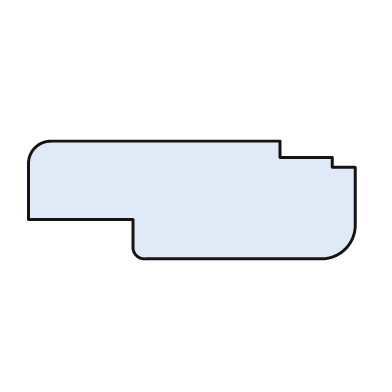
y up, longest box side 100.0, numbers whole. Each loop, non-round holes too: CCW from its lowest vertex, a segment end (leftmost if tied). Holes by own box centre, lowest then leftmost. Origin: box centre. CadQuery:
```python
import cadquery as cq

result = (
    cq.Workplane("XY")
    .moveTo(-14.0, -18.0)
    .lineTo(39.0, -18.0)
    .threePointArc((47.0, -15.0), (50.0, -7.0))
    .lineTo(50.0, 10.0)
    .lineTo(43.0, 10.0)
    .lineTo(43.0, 13.0)
    .lineTo(27.0, 13.0)
    .lineTo(27.0, 18.0)
    .lineTo(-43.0, 18.0)
    .threePointArc((-48.0, 16.0), (-50.0, 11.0))
    .lineTo(-50.0, -6.0)
    .lineTo(-18.0, -6.0)
    .lineTo(-18.0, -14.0)
    .threePointArc((-17.0, -17.0), (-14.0, -18.0))
    .close()
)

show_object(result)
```